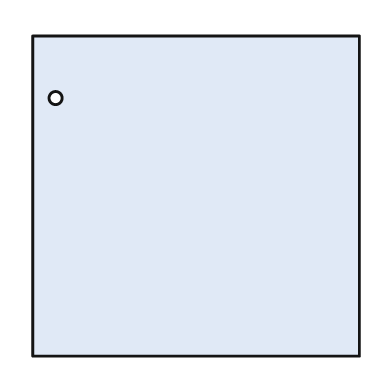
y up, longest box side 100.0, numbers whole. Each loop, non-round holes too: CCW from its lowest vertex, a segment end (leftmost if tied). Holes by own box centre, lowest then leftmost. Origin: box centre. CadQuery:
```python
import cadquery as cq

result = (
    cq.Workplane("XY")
    .moveTo(-50.0, -49.0)
    .lineTo(50.0, -49.0)
    .lineTo(50.0, 49.0)
    .lineTo(-50.0, 49.0)
    .close()
    .moveTo(-43.0, 30.0)
    .circle(2.0)
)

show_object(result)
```